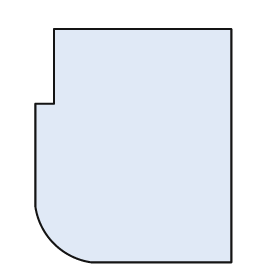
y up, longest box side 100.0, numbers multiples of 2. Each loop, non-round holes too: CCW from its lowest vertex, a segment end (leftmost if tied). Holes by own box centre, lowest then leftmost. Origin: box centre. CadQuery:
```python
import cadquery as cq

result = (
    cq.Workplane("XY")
    .moveTo(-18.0, -50.0)
    .lineTo(42.0, -50.0)
    .lineTo(42.0, 50.0)
    .lineTo(-34.0, 50.0)
    .lineTo(-34.0, 18.0)
    .lineTo(-42.0, 18.0)
    .lineTo(-42.0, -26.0)
    .threePointArc((-34.0, -42.0), (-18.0, -50.0))
    .close()
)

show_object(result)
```